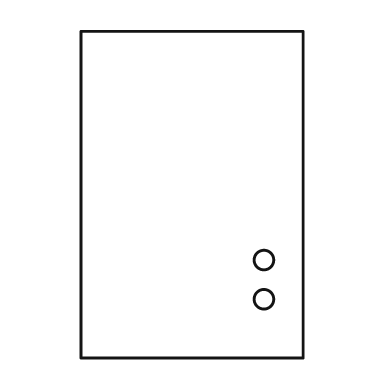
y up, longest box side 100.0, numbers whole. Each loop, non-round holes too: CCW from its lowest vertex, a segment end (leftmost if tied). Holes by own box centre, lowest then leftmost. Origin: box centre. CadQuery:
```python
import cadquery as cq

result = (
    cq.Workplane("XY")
    .moveTo(-34.0, -50.0)
    .lineTo(34.0, -50.0)
    .lineTo(34.0, 50.0)
    .lineTo(-34.0, 50.0)
    .close()
    .moveTo(22.0, -32.0)
    .circle(3.0)
    .moveTo(22.0, -20.0)
    .circle(3.0)
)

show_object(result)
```